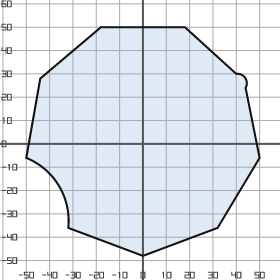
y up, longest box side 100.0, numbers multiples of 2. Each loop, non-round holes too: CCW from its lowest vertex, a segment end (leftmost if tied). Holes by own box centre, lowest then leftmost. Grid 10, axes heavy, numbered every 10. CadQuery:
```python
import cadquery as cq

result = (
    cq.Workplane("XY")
    .moveTo(0.0, -48.0)
    .lineTo(32.0, -36.0)
    .lineTo(50.0, -6.0)
    .lineTo(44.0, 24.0)
    .threePointArc((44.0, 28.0), (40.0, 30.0))
    .lineTo(18.0, 50.0)
    .lineTo(-18.0, 50.0)
    .lineTo(-44.0, 28.0)
    .lineTo(-50.0, -6.0)
    .threePointArc((-36.0, -18.0), (-32.0, -36.0))
    .close()
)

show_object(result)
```